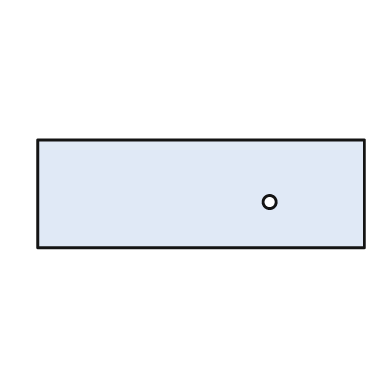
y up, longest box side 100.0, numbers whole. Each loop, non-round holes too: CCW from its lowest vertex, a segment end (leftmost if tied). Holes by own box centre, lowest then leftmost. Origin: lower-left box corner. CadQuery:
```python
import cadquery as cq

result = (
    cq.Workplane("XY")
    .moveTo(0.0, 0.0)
    .lineTo(100.0, 0.0)
    .lineTo(100.0, 33.0)
    .lineTo(0.0, 33.0)
    .close()
    .moveTo(71.0, 14.0)
    .circle(2.0)
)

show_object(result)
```